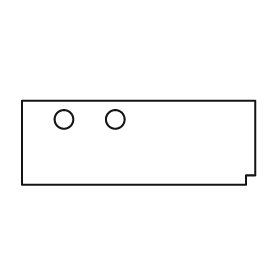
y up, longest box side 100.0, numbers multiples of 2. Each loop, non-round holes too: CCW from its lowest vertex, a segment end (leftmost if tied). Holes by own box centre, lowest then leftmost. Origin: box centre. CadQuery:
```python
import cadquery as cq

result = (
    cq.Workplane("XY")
    .moveTo(-50.0, -18.0)
    .lineTo(46.0, -18.0)
    .lineTo(46.0, -14.0)
    .lineTo(50.0, -14.0)
    .lineTo(50.0, 18.0)
    .lineTo(-50.0, 18.0)
    .close()
    .moveTo(-32.0, 10.0)
    .circle(4.0)
    .moveTo(-10.0, 10.0)
    .circle(4.0)
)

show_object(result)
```